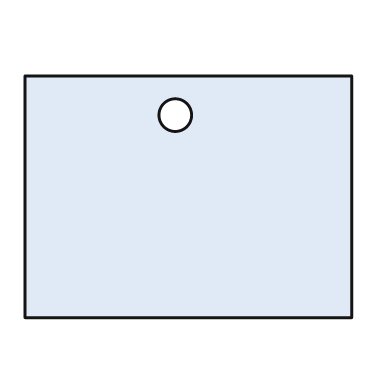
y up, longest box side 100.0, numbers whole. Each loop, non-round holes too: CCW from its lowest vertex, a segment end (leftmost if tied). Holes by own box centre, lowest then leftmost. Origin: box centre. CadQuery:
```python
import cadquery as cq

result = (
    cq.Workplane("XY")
    .moveTo(-50.0, -37.0)
    .lineTo(50.0, -37.0)
    .lineTo(50.0, 37.0)
    .lineTo(-50.0, 37.0)
    .close()
    .moveTo(-4.0, 25.0)
    .circle(5.0)
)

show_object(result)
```